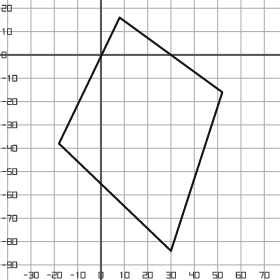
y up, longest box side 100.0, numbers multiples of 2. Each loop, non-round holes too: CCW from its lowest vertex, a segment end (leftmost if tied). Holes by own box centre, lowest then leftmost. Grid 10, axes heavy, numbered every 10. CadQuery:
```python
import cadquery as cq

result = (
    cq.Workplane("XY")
    .moveTo(30.0, -84.0)
    .lineTo(52.0, -16.0)
    .lineTo(8.0, 16.0)
    .lineTo(-18.0, -38.0)
    .close()
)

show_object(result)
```